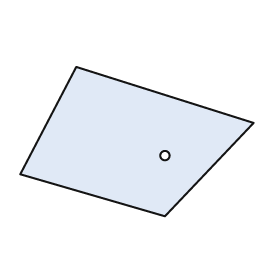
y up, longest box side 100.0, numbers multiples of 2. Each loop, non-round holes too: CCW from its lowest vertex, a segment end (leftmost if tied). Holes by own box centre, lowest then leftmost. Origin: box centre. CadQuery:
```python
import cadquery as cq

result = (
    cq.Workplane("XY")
    .moveTo(12.0, -32.0)
    .lineTo(50.0, 8.0)
    .lineTo(-26.0, 32.0)
    .lineTo(-50.0, -14.0)
    .close()
    .moveTo(12.0, -6.0)
    .circle(2.0)
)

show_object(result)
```